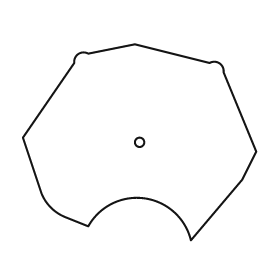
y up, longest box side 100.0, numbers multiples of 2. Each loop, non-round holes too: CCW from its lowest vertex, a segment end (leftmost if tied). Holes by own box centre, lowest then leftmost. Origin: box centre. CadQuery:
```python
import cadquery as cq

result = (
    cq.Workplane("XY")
    .moveTo(22.0, -42.0)
    .lineTo(44.0, -16.0)
    .lineTo(50.0, -4.0)
    .lineTo(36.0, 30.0)
    .threePointArc((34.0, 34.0), (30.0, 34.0))
    .lineTo(-2.0, 42.0)
    .lineTo(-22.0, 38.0)
    .threePointArc((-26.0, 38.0), (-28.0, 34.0))
    .lineTo(-50.0, 2.0)
    .lineTo(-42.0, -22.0)
    .threePointArc((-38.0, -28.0), (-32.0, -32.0))
    .lineTo(-22.0, -36.0)
    .threePointArc((2.0, -24.0), (22.0, -42.0))
    .close()
    .moveTo(0.0, 0.0)
    .circle(2.0)
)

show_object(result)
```